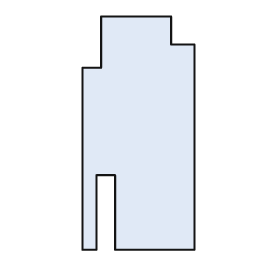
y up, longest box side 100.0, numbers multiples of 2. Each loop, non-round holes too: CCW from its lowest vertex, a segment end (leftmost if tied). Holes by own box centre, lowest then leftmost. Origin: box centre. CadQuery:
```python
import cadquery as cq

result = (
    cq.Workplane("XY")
    .moveTo(-24.0, -50.0)
    .lineTo(-18.0, -50.0)
    .lineTo(-18.0, -18.0)
    .lineTo(-10.0, -18.0)
    .lineTo(-10.0, -50.0)
    .lineTo(24.0, -50.0)
    .lineTo(24.0, 38.0)
    .lineTo(14.0, 38.0)
    .lineTo(14.0, 50.0)
    .lineTo(-16.0, 50.0)
    .lineTo(-16.0, 28.0)
    .lineTo(-24.0, 28.0)
    .close()
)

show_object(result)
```